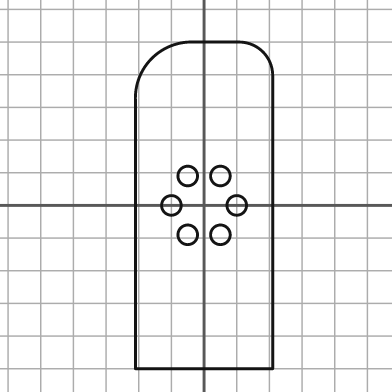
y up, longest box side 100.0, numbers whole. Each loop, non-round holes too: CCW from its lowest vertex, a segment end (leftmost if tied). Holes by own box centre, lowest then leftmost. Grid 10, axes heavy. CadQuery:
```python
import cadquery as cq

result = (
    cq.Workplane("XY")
    .moveTo(-21.0, -50.0)
    .lineTo(21.0, -50.0)
    .lineTo(21.0, 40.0)
    .threePointArc((18.0, 47.0), (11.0, 50.0))
    .lineTo(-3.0, 50.0)
    .threePointArc((-16.0, 45.0), (-21.0, 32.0))
    .close()
    .moveTo(-5.0, -9.0)
    .circle(3.0)
    .moveTo(5.0, -9.0)
    .circle(3.0)
    .moveTo(-10.0, 0.0)
    .circle(3.0)
    .moveTo(10.0, 0.0)
    .circle(3.0)
    .moveTo(-5.0, 9.0)
    .circle(3.0)
    .moveTo(5.0, 9.0)
    .circle(3.0)
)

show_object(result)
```